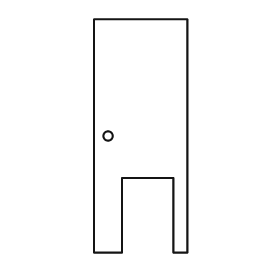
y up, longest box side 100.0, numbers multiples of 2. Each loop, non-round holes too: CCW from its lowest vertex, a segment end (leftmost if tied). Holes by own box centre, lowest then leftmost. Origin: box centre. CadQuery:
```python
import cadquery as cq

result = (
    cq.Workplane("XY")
    .moveTo(-20.0, -50.0)
    .lineTo(-8.0, -50.0)
    .lineTo(-8.0, -18.0)
    .lineTo(14.0, -18.0)
    .lineTo(14.0, -50.0)
    .lineTo(20.0, -50.0)
    .lineTo(20.0, 50.0)
    .lineTo(-20.0, 50.0)
    .close()
    .moveTo(-14.0, 0.0)
    .circle(2.0)
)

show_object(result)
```